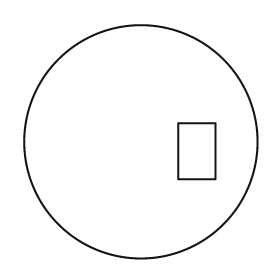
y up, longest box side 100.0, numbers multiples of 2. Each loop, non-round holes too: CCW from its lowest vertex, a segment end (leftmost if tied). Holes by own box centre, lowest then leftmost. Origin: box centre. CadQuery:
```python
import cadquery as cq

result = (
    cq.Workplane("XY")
    .moveTo(0.0, 0.0)
    .circle(50.0)
    .moveTo(16.0, -16.0)
    .lineTo(32.0, -16.0)
    .lineTo(32.0, 8.0)
    .lineTo(16.0, 8.0)
    .close()
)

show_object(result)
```